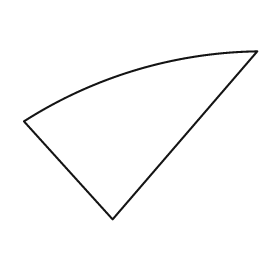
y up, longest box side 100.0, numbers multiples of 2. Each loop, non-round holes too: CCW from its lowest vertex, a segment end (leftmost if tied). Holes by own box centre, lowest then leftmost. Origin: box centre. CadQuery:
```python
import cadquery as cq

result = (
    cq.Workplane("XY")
    .moveTo(-12.0, -36.0)
    .lineTo(50.0, 36.0)
    .threePointArc((-2.0, 28.0), (-50.0, 6.0))
    .close()
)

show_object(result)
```